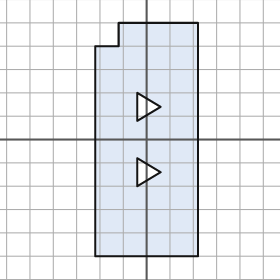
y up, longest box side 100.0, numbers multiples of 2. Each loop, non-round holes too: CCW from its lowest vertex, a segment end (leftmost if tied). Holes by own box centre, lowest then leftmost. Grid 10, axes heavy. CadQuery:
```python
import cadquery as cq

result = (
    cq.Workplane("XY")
    .moveTo(-22.0, -50.0)
    .lineTo(22.0, -50.0)
    .lineTo(22.0, 50.0)
    .lineTo(-12.0, 50.0)
    .lineTo(-12.0, 40.0)
    .lineTo(-22.0, 40.0)
    .close()
    .moveTo(-4.0, -20.0)
    .lineTo(6.0, -14.0)
    .lineTo(-4.0, -8.0)
    .close()
    .moveTo(-4.0, 8.0)
    .lineTo(6.0, 14.0)
    .lineTo(-4.0, 20.0)
    .close()
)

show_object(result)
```